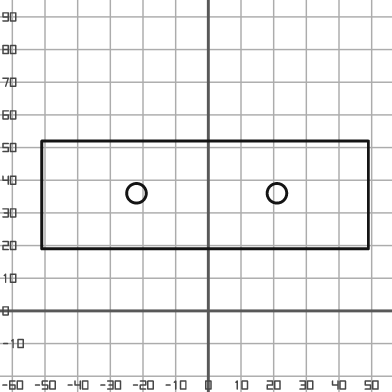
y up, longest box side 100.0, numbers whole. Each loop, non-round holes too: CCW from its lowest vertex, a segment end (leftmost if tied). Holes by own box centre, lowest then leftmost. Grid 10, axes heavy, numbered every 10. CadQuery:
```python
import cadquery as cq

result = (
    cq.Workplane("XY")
    .moveTo(-51.0, 19.0)
    .lineTo(49.0, 19.0)
    .lineTo(49.0, 52.0)
    .lineTo(-51.0, 52.0)
    .close()
    .moveTo(-22.0, 36.0)
    .circle(3.0)
    .moveTo(21.0, 36.0)
    .circle(3.0)
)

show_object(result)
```